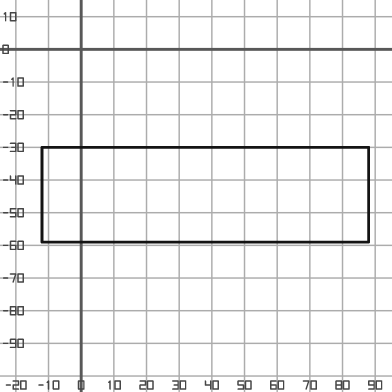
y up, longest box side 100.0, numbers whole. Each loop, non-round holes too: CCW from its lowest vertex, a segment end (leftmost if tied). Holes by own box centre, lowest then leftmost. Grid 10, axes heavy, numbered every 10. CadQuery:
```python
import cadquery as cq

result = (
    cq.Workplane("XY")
    .moveTo(-12.0, -59.0)
    .lineTo(88.0, -59.0)
    .lineTo(88.0, -30.0)
    .lineTo(-12.0, -30.0)
    .close()
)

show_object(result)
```